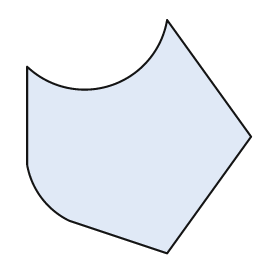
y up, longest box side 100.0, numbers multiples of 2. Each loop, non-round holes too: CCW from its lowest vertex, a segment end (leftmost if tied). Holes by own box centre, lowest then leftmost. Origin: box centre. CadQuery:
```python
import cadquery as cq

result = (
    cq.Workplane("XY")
    .moveTo(12.0, -50.0)
    .lineTo(48.0, 0.0)
    .lineTo(12.0, 50.0)
    .threePointArc((-12.0, 22.0), (-48.0, 30.0))
    .lineTo(-48.0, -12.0)
    .threePointArc((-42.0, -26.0), (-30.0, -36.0))
    .close()
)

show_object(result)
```